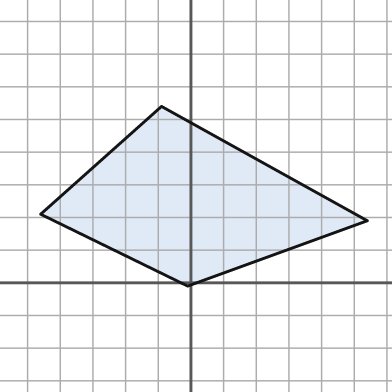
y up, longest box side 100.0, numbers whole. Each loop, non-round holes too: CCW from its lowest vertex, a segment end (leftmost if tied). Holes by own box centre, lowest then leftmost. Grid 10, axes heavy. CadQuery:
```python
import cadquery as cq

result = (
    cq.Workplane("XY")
    .moveTo(-1.0, -1.0)
    .lineTo(54.0, 19.0)
    .lineTo(-9.0, 54.0)
    .lineTo(-46.0, 21.0)
    .close()
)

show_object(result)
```